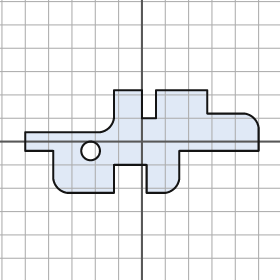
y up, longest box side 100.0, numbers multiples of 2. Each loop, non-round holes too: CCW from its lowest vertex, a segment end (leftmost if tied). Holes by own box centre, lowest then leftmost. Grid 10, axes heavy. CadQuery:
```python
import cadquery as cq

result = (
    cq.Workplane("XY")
    .moveTo(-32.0, -22.0)
    .lineTo(-12.0, -22.0)
    .lineTo(-12.0, -10.0)
    .lineTo(2.0, -10.0)
    .lineTo(2.0, -22.0)
    .lineTo(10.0, -22.0)
    .threePointArc((14.0, -20.0), (16.0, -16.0))
    .lineTo(16.0, -4.0)
    .lineTo(50.0, -4.0)
    .lineTo(50.0, 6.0)
    .threePointArc((48.0, 10.0), (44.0, 12.0))
    .lineTo(28.0, 12.0)
    .lineTo(28.0, 22.0)
    .lineTo(6.0, 22.0)
    .lineTo(6.0, 10.0)
    .lineTo(0.0, 10.0)
    .lineTo(0.0, 22.0)
    .lineTo(-12.0, 22.0)
    .lineTo(-12.0, 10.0)
    .threePointArc((-14.0, 6.0), (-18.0, 4.0))
    .lineTo(-50.0, 4.0)
    .lineTo(-50.0, -4.0)
    .lineTo(-38.0, -4.0)
    .lineTo(-38.0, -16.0)
    .threePointArc((-36.0, -20.0), (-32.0, -22.0))
    .close()
    .moveTo(-22.0, -4.0)
    .circle(4.0)
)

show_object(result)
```